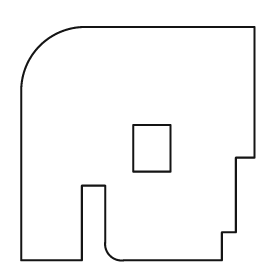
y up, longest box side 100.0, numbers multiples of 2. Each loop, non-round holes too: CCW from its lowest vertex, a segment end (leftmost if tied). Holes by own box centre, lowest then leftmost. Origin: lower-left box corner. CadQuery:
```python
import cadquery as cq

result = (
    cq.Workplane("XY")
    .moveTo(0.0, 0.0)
    .lineTo(26.0, 0.0)
    .lineTo(26.0, 32.0)
    .lineTo(36.0, 32.0)
    .lineTo(36.0, 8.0)
    .threePointArc((38.0, 2.0), (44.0, 0.0))
    .lineTo(86.0, 0.0)
    .lineTo(86.0, 12.0)
    .lineTo(92.0, 12.0)
    .lineTo(92.0, 44.0)
    .lineTo(100.0, 44.0)
    .lineTo(100.0, 100.0)
    .lineTo(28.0, 100.0)
    .threePointArc((8.0, 92.0), (0.0, 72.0))
    .close()
    .moveTo(48.0, 38.0)
    .lineTo(64.0, 38.0)
    .lineTo(64.0, 58.0)
    .lineTo(48.0, 58.0)
    .close()
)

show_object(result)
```